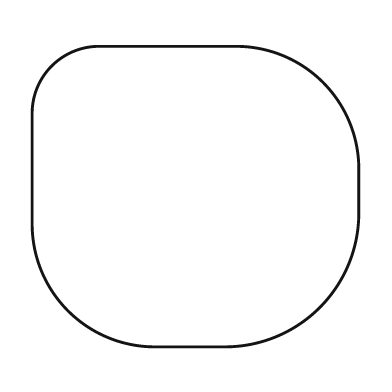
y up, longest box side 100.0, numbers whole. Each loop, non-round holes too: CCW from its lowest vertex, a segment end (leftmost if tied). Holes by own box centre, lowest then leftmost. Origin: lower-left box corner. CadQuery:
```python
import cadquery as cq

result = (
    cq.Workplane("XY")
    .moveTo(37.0, 0.0)
    .lineTo(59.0, 0.0)
    .threePointArc((88.0, 12.0), (100.0, 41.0))
    .lineTo(100.0, 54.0)
    .threePointArc((89.0, 81.0), (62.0, 92.0))
    .lineTo(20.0, 92.0)
    .threePointArc((6.0, 86.0), (0.0, 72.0))
    .lineTo(0.0, 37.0)
    .threePointArc((11.0, 11.0), (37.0, 0.0))
    .close()
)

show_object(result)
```